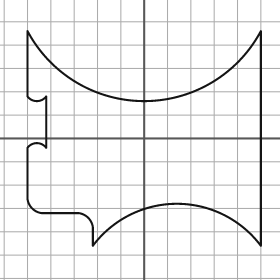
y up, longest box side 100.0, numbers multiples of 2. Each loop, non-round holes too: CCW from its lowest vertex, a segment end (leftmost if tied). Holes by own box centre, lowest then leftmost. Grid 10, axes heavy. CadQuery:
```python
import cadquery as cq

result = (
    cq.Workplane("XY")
    .moveTo(-22.0, -46.0)
    .threePointArc((14.0, -28.0), (50.0, -46.0))
    .lineTo(50.0, 46.0)
    .threePointArc((0.0, 16.0), (-50.0, 46.0))
    .lineTo(-50.0, 18.0)
    .threePointArc((-46.0, 16.0), (-42.0, 18.0))
    .lineTo(-42.0, -4.0)
    .threePointArc((-46.0, -2.0), (-50.0, -4.0))
    .lineTo(-50.0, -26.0)
    .threePointArc((-48.0, -30.0), (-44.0, -32.0))
    .lineTo(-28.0, -32.0)
    .threePointArc((-24.0, -34.0), (-22.0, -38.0))
    .close()
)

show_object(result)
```